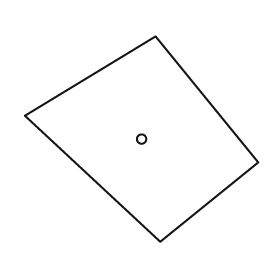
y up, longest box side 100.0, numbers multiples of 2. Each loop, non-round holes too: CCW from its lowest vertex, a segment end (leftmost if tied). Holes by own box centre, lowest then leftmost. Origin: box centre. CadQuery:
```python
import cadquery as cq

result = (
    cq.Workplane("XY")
    .moveTo(8.0, -44.0)
    .lineTo(50.0, -10.0)
    .lineTo(6.0, 44.0)
    .lineTo(-50.0, 10.0)
    .close()
    .moveTo(0.0, 0.0)
    .circle(2.0)
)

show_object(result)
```